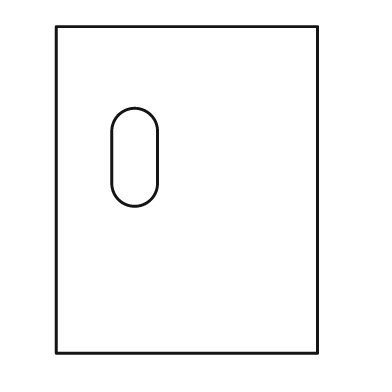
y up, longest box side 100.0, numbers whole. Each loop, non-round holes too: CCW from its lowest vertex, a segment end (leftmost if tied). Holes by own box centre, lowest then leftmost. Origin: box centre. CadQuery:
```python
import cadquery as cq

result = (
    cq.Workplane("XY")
    .moveTo(-40.0, -50.0)
    .lineTo(40.0, -50.0)
    .lineTo(40.0, 50.0)
    .lineTo(-40.0, 50.0)
    .close()
    .moveTo(-23.0, 2.0)
    .threePointArc((-16.0, -5.0), (-9.0, 2.0))
    .lineTo(-9.0, 18.0)
    .threePointArc((-16.0, 25.0), (-23.0, 18.0))
    .close()
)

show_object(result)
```